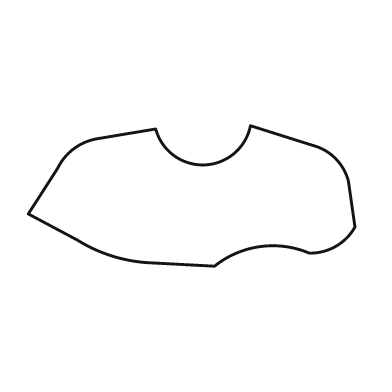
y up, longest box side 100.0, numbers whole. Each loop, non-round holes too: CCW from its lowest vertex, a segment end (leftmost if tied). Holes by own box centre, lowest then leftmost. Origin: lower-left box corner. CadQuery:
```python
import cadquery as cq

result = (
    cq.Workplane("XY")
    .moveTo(57.0, 0.0)
    .threePointArc((71.0, 6.0), (86.0, 4.0))
    .threePointArc((94.0, 6.0), (100.0, 12.0))
    .lineTo(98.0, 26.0)
    .threePointArc((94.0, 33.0), (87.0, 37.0))
    .lineTo(68.0, 43.0)
    .threePointArc((54.0, 31.0), (39.0, 42.0))
    .lineTo(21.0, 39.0)
    .threePointArc((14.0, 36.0), (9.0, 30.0))
    .lineTo(0.0, 16.0)
    .lineTo(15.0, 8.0)
    .threePointArc((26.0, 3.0), (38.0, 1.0))
    .close()
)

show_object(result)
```